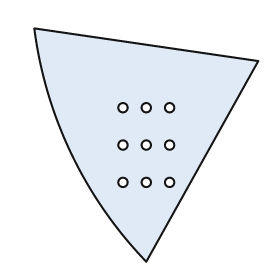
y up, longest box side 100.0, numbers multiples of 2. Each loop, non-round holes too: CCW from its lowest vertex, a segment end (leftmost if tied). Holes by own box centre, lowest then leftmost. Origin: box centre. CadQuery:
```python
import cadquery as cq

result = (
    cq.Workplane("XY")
    .moveTo(0.0, -50.0)
    .lineTo(48.0, 36.0)
    .lineTo(-48.0, 50.0)
    .threePointArc((-32.0, -4.0), (0.0, -50.0))
    .close()
    .moveTo(-10.0, -16.0)
    .circle(2.0)
    .moveTo(0.0, -16.0)
    .circle(2.0)
    .moveTo(10.0, -16.0)
    .circle(2.0)
    .moveTo(-10.0, 0.0)
    .circle(2.0)
    .moveTo(0.0, 0.0)
    .circle(2.0)
    .moveTo(10.0, 0.0)
    .circle(2.0)
    .moveTo(-10.0, 16.0)
    .circle(2.0)
    .moveTo(0.0, 16.0)
    .circle(2.0)
    .moveTo(10.0, 16.0)
    .circle(2.0)
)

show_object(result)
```